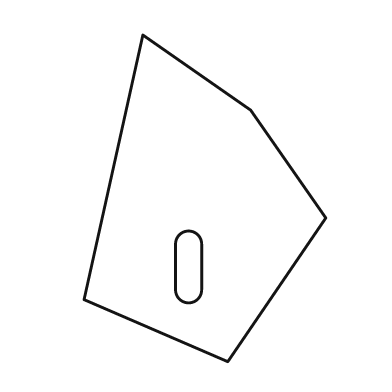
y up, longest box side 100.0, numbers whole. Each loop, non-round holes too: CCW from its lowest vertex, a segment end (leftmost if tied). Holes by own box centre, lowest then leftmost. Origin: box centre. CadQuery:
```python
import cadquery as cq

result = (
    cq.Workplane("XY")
    .moveTo(7.0, -50.0)
    .lineTo(37.0, -6.0)
    .lineTo(14.0, 27.0)
    .lineTo(-19.0, 50.0)
    .lineTo(-37.0, -31.0)
    .close()
    .moveTo(-9.0, -28.0)
    .threePointArc((-5.0, -32.0), (-1.0, -28.0))
    .lineTo(-1.0, -14.0)
    .threePointArc((-5.0, -10.0), (-9.0, -14.0))
    .close()
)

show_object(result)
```